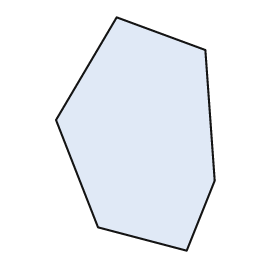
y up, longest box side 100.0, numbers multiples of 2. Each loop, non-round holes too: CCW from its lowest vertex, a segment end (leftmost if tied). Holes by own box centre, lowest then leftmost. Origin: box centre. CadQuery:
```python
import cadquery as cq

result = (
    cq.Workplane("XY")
    .moveTo(22.0, -50.0)
    .lineTo(34.0, -20.0)
    .lineTo(30.0, 36.0)
    .lineTo(-8.0, 50.0)
    .lineTo(-34.0, 6.0)
    .lineTo(-16.0, -40.0)
    .close()
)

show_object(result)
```